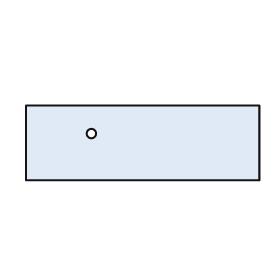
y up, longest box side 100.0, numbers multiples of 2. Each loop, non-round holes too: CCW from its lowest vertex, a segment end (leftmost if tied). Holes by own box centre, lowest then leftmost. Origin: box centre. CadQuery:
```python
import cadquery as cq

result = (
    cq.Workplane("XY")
    .moveTo(-50.0, -16.0)
    .lineTo(50.0, -16.0)
    .lineTo(50.0, 16.0)
    .lineTo(-50.0, 16.0)
    .close()
    .moveTo(-22.0, 4.0)
    .circle(2.0)
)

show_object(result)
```